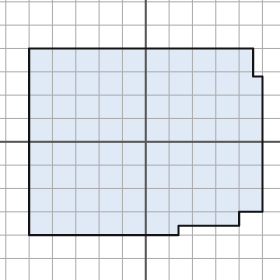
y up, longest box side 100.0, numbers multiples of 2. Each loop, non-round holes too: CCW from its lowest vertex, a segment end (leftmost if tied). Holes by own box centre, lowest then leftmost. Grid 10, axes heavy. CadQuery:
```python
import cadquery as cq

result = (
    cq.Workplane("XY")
    .moveTo(-50.0, -40.0)
    .lineTo(14.0, -40.0)
    .lineTo(14.0, -36.0)
    .lineTo(40.0, -36.0)
    .lineTo(40.0, -30.0)
    .lineTo(50.0, -30.0)
    .lineTo(50.0, 28.0)
    .lineTo(46.0, 28.0)
    .lineTo(46.0, 40.0)
    .lineTo(-50.0, 40.0)
    .close()
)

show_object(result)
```